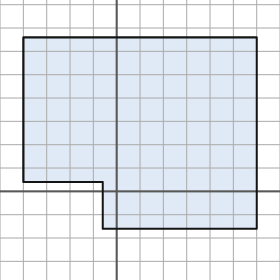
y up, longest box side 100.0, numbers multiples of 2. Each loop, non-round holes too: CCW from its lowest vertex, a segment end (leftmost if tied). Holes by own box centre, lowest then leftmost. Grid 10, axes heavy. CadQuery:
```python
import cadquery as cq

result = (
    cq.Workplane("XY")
    .moveTo(-6.0, -16.0)
    .lineTo(60.0, -16.0)
    .lineTo(60.0, 66.0)
    .lineTo(-40.0, 66.0)
    .lineTo(-40.0, 4.0)
    .lineTo(-6.0, 4.0)
    .close()
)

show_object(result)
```